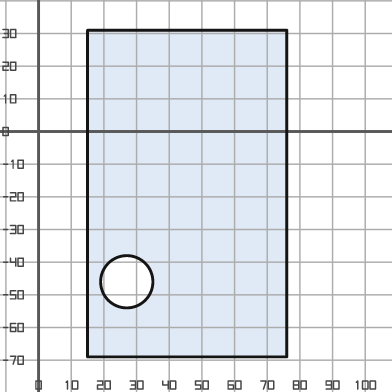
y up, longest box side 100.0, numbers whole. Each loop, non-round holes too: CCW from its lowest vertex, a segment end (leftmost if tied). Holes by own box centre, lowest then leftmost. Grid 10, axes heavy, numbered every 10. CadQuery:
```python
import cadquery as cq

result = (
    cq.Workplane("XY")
    .moveTo(15.0, -69.0)
    .lineTo(76.0, -69.0)
    .lineTo(76.0, 31.0)
    .lineTo(15.0, 31.0)
    .close()
    .moveTo(27.0, -46.0)
    .circle(8.0)
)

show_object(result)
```